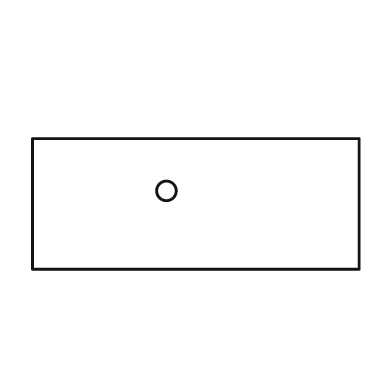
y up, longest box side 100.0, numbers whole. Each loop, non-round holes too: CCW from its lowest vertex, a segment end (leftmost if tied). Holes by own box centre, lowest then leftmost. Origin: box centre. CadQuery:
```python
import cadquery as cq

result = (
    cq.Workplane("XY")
    .moveTo(-50.0, -20.0)
    .lineTo(50.0, -20.0)
    .lineTo(50.0, 20.0)
    .lineTo(-50.0, 20.0)
    .close()
    .moveTo(-9.0, 4.0)
    .circle(3.0)
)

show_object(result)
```